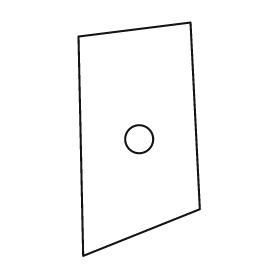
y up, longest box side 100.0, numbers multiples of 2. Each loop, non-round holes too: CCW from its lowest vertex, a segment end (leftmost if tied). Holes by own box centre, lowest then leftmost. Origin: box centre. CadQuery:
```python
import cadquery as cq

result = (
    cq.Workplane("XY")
    .moveTo(-24.0, -50.0)
    .lineTo(26.0, -30.0)
    .lineTo(22.0, 50.0)
    .lineTo(-26.0, 44.0)
    .close()
    .moveTo(0.0, 0.0)
    .circle(6.0)
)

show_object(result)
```